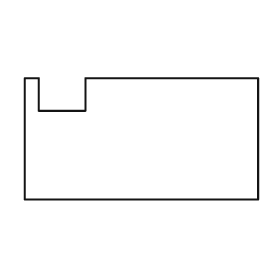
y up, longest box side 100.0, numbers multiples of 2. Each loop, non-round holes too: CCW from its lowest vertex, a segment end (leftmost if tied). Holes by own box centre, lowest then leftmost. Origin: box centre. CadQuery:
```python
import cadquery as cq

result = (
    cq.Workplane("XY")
    .moveTo(-50.0, -26.0)
    .lineTo(50.0, -26.0)
    .lineTo(50.0, 26.0)
    .lineTo(-24.0, 26.0)
    .lineTo(-24.0, 12.0)
    .lineTo(-44.0, 12.0)
    .lineTo(-44.0, 26.0)
    .lineTo(-50.0, 26.0)
    .close()
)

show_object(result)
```